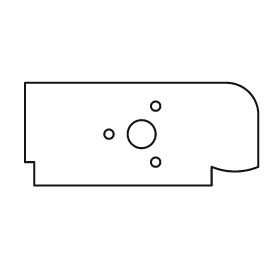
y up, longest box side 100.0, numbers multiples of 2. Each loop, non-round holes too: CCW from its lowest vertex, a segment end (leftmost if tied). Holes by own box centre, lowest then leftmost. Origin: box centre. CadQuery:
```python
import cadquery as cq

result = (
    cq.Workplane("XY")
    .moveTo(-46.0, -22.0)
    .lineTo(30.0, -22.0)
    .lineTo(30.0, -14.0)
    .threePointArc((40.0, -16.0), (50.0, -14.0))
    .lineTo(50.0, 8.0)
    .threePointArc((46.0, 18.0), (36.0, 22.0))
    .lineTo(-50.0, 22.0)
    .lineTo(-50.0, -12.0)
    .lineTo(-46.0, -12.0)
    .close()
    .moveTo(6.0, -12.0)
    .circle(2.0)
    .moveTo(-14.0, 0.0)
    .circle(2.0)
    .moveTo(0.0, 0.0)
    .circle(6.0)
    .moveTo(6.0, 12.0)
    .circle(2.0)
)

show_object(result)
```